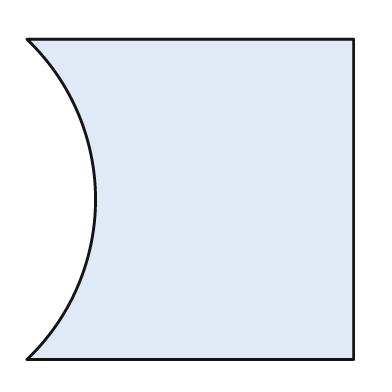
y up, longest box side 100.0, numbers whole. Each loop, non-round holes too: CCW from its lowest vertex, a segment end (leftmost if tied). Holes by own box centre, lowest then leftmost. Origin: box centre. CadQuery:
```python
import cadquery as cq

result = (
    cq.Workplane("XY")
    .moveTo(-50.0, -49.0)
    .lineTo(50.0, -49.0)
    .lineTo(50.0, 49.0)
    .lineTo(-50.0, 49.0)
    .threePointArc((-29.0, 0.0), (-50.0, -49.0))
    .close()
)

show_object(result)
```